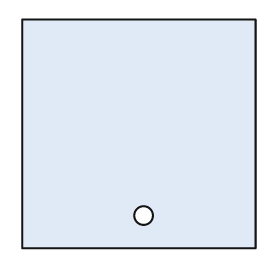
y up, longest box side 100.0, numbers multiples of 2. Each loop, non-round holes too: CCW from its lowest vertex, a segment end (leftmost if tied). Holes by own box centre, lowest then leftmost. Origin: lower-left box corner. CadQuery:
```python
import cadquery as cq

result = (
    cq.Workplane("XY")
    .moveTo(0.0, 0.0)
    .lineTo(100.0, 0.0)
    .lineTo(100.0, 98.0)
    .lineTo(0.0, 98.0)
    .close()
    .moveTo(52.0, 14.0)
    .circle(4.0)
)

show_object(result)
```